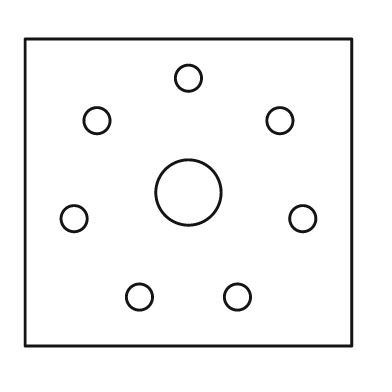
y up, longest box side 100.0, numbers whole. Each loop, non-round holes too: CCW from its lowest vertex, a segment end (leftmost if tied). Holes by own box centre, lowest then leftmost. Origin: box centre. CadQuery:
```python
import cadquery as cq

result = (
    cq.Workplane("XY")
    .moveTo(-50.0, -47.0)
    .lineTo(50.0, -47.0)
    .lineTo(50.0, 47.0)
    .lineTo(-50.0, 47.0)
    .close()
    .moveTo(-15.0, -32.0)
    .circle(4.0)
    .moveTo(15.0, -32.0)
    .circle(4.0)
    .moveTo(-35.0, -8.0)
    .circle(4.0)
    .moveTo(35.0, -8.0)
    .circle(4.0)
    .moveTo(0.0, 0.0)
    .circle(10.0)
    .moveTo(-28.0, 22.0)
    .circle(4.0)
    .moveTo(28.0, 22.0)
    .circle(4.0)
    .moveTo(0.0, 35.0)
    .circle(4.0)
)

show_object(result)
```